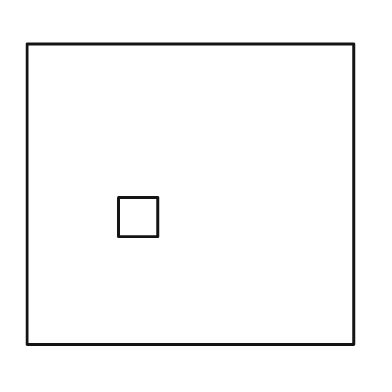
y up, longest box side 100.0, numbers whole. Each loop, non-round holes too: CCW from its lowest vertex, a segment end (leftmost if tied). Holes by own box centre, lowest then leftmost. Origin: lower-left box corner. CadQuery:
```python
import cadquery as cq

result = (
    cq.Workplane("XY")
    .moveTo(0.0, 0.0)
    .lineTo(100.0, 0.0)
    .lineTo(100.0, 92.0)
    .lineTo(0.0, 92.0)
    .close()
    .moveTo(28.0, 33.0)
    .lineTo(40.0, 33.0)
    .lineTo(40.0, 45.0)
    .lineTo(28.0, 45.0)
    .close()
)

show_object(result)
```